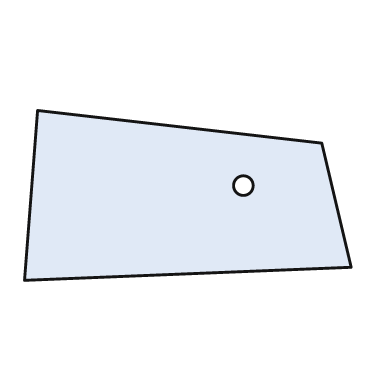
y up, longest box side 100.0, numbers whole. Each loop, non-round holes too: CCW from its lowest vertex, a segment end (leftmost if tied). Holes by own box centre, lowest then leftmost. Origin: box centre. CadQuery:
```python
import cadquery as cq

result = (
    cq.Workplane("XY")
    .moveTo(-50.0, -26.0)
    .lineTo(50.0, -22.0)
    .lineTo(41.0, 16.0)
    .lineTo(-46.0, 26.0)
    .close()
    .moveTo(17.0, 3.0)
    .circle(3.0)
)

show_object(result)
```